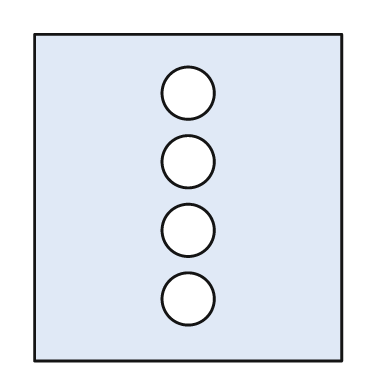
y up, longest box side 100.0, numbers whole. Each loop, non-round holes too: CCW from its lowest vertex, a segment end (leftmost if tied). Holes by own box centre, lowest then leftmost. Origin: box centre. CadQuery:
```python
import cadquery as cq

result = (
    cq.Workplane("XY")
    .moveTo(-47.0, -50.0)
    .lineTo(47.0, -50.0)
    .lineTo(47.0, 50.0)
    .lineTo(-47.0, 50.0)
    .close()
    .moveTo(0.0, -31.0)
    .circle(8.0)
    .moveTo(0.0, -10.0)
    .circle(8.0)
    .moveTo(0.0, 11.0)
    .circle(8.0)
    .moveTo(0.0, 32.0)
    .circle(8.0)
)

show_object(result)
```